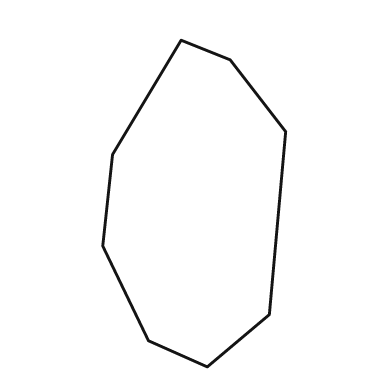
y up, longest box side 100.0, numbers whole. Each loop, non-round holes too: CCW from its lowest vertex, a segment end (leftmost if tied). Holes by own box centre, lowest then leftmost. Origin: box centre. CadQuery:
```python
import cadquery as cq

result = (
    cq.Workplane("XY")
    .moveTo(4.0, -50.0)
    .lineTo(23.0, -34.0)
    .lineTo(28.0, 22.0)
    .lineTo(11.0, 44.0)
    .lineTo(-4.0, 50.0)
    .lineTo(-25.0, 15.0)
    .lineTo(-28.0, -13.0)
    .lineTo(-14.0, -42.0)
    .close()
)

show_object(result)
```